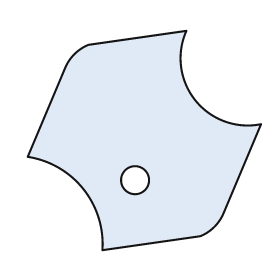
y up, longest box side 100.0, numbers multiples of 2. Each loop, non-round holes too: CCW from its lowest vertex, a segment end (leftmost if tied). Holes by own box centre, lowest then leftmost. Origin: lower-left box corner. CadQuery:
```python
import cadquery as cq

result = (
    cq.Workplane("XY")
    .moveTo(32.0, 0.0)
    .lineTo(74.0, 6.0)
    .threePointArc((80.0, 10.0), (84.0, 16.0))
    .lineTo(100.0, 54.0)
    .threePointArc((72.0, 64.0), (68.0, 94.0))
    .lineTo(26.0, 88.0)
    .threePointArc((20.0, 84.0), (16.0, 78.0))
    .lineTo(0.0, 40.0)
    .threePointArc((24.0, 26.0), (32.0, 0.0))
    .close()
    .moveTo(46.0, 30.0)
    .circle(6.0)
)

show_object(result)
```